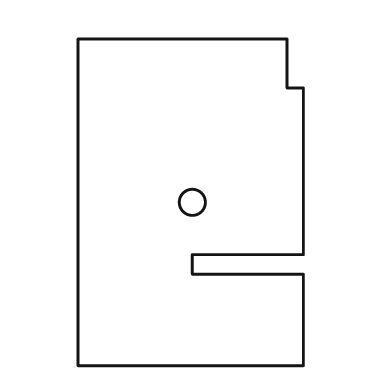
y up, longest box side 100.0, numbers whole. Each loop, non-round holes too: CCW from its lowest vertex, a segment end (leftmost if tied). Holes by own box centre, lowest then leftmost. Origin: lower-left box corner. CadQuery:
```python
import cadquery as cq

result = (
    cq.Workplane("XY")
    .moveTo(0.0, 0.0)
    .lineTo(69.0, 0.0)
    .lineTo(69.0, 28.0)
    .lineTo(35.0, 28.0)
    .lineTo(35.0, 34.0)
    .lineTo(69.0, 34.0)
    .lineTo(69.0, 85.0)
    .lineTo(64.0, 85.0)
    .lineTo(64.0, 100.0)
    .lineTo(0.0, 100.0)
    .close()
    .moveTo(35.0, 50.0)
    .circle(4.0)
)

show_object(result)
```